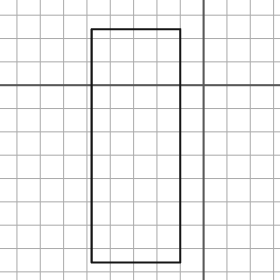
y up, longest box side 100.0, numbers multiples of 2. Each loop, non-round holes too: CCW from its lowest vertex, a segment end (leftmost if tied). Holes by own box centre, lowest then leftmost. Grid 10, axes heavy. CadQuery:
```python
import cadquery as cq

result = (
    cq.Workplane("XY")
    .moveTo(-48.0, -76.0)
    .lineTo(-10.0, -76.0)
    .lineTo(-10.0, 24.0)
    .lineTo(-48.0, 24.0)
    .close()
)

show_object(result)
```